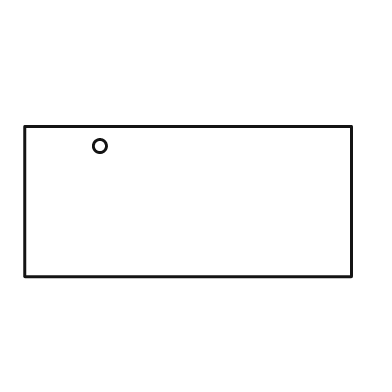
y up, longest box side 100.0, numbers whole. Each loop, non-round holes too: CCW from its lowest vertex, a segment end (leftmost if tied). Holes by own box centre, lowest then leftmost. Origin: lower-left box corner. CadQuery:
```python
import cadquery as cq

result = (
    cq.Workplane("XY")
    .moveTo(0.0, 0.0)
    .lineTo(100.0, 0.0)
    .lineTo(100.0, 46.0)
    .lineTo(0.0, 46.0)
    .close()
    .moveTo(23.0, 40.0)
    .circle(2.0)
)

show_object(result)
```